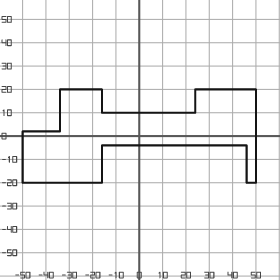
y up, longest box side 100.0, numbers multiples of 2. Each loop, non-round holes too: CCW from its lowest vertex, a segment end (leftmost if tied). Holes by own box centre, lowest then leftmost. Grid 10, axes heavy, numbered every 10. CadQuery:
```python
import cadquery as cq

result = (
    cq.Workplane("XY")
    .moveTo(-50.0, -20.0)
    .lineTo(-16.0, -20.0)
    .lineTo(-16.0, -4.0)
    .lineTo(46.0, -4.0)
    .lineTo(46.0, -20.0)
    .lineTo(50.0, -20.0)
    .lineTo(50.0, 20.0)
    .lineTo(24.0, 20.0)
    .lineTo(24.0, 10.0)
    .lineTo(-16.0, 10.0)
    .lineTo(-16.0, 20.0)
    .lineTo(-34.0, 20.0)
    .lineTo(-34.0, 2.0)
    .lineTo(-50.0, 2.0)
    .close()
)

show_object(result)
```